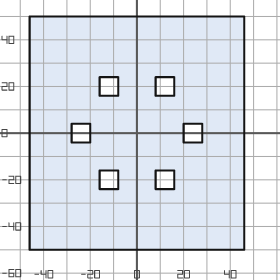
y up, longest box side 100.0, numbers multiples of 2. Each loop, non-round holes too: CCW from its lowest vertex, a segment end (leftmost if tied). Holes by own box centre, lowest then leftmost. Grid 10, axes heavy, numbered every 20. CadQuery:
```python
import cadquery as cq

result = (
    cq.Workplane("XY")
    .moveTo(-46.0, -50.0)
    .lineTo(46.0, -50.0)
    .lineTo(46.0, 50.0)
    .lineTo(-46.0, 50.0)
    .close()
    .moveTo(-16.0, -24.0)
    .lineTo(-8.0, -24.0)
    .lineTo(-8.0, -16.0)
    .lineTo(-16.0, -16.0)
    .close()
    .moveTo(8.0, -24.0)
    .lineTo(16.0, -24.0)
    .lineTo(16.0, -16.0)
    .lineTo(8.0, -16.0)
    .close()
    .moveTo(-28.0, -4.0)
    .lineTo(-20.0, -4.0)
    .lineTo(-20.0, 4.0)
    .lineTo(-28.0, 4.0)
    .close()
    .moveTo(20.0, -4.0)
    .lineTo(28.0, -4.0)
    .lineTo(28.0, 4.0)
    .lineTo(20.0, 4.0)
    .close()
    .moveTo(-16.0, 16.0)
    .lineTo(-8.0, 16.0)
    .lineTo(-8.0, 24.0)
    .lineTo(-16.0, 24.0)
    .close()
    .moveTo(8.0, 16.0)
    .lineTo(16.0, 16.0)
    .lineTo(16.0, 24.0)
    .lineTo(8.0, 24.0)
    .close()
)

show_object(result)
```